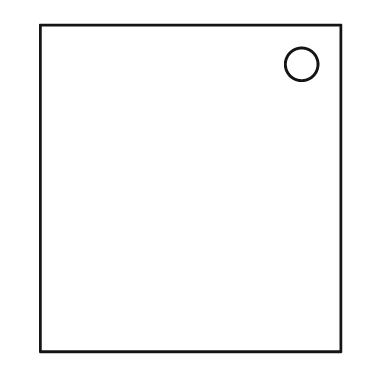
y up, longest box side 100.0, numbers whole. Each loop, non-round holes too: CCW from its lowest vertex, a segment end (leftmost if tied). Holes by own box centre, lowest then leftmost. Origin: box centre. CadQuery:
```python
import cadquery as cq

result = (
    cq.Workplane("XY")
    .moveTo(-46.0, -50.0)
    .lineTo(46.0, -50.0)
    .lineTo(46.0, 50.0)
    .lineTo(-46.0, 50.0)
    .close()
    .moveTo(34.0, 38.0)
    .circle(5.0)
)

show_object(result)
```